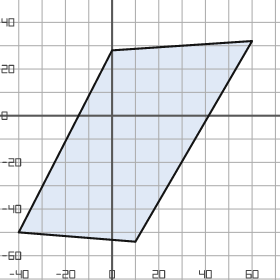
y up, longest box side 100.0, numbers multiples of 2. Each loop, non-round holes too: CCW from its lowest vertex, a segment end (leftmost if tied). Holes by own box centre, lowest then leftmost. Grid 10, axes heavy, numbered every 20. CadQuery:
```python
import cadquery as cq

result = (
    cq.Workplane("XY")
    .moveTo(10.0, -54.0)
    .lineTo(60.0, 32.0)
    .lineTo(0.0, 28.0)
    .lineTo(-40.0, -50.0)
    .close()
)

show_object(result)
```